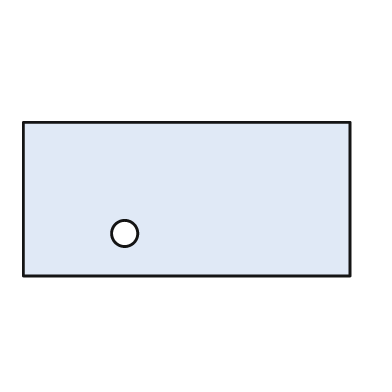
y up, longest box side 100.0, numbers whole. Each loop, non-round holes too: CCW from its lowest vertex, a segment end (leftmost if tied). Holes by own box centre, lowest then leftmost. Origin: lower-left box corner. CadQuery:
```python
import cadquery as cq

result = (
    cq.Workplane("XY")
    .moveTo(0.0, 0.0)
    .lineTo(100.0, 0.0)
    .lineTo(100.0, 47.0)
    .lineTo(0.0, 47.0)
    .close()
    .moveTo(31.0, 13.0)
    .circle(4.0)
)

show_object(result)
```